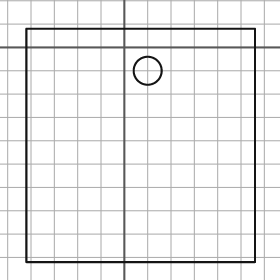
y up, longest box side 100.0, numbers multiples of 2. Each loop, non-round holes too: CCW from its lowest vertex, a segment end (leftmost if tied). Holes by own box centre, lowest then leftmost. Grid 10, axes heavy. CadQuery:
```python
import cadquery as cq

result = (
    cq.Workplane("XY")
    .moveTo(-42.0, -92.0)
    .lineTo(56.0, -92.0)
    .lineTo(56.0, 8.0)
    .lineTo(-42.0, 8.0)
    .close()
    .moveTo(10.0, -10.0)
    .circle(6.0)
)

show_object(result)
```